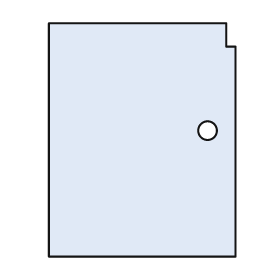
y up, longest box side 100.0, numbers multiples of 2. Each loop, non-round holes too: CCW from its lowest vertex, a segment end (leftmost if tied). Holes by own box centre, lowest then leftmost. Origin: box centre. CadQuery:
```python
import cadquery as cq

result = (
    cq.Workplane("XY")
    .moveTo(-40.0, -50.0)
    .lineTo(40.0, -50.0)
    .lineTo(40.0, 40.0)
    .lineTo(36.0, 40.0)
    .lineTo(36.0, 50.0)
    .lineTo(-40.0, 50.0)
    .close()
    .moveTo(28.0, 4.0)
    .circle(4.0)
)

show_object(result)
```